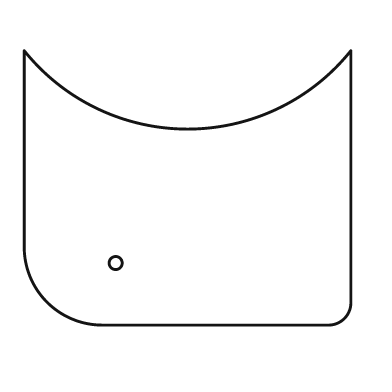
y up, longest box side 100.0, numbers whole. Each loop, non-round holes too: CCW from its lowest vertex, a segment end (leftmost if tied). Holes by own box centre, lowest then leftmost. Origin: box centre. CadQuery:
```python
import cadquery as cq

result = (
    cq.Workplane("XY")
    .moveTo(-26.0, -42.0)
    .lineTo(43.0, -42.0)
    .threePointArc((48.0, -40.0), (50.0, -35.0))
    .lineTo(50.0, 42.0)
    .threePointArc((0.0, 18.0), (-50.0, 42.0))
    .lineTo(-50.0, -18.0)
    .threePointArc((-43.0, -35.0), (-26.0, -42.0))
    .close()
    .moveTo(-22.0, -23.0)
    .circle(2.0)
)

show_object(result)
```